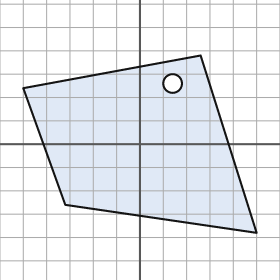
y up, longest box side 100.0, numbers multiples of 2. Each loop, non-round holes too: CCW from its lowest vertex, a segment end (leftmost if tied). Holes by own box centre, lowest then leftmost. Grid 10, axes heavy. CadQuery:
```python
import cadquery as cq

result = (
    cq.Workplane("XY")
    .moveTo(50.0, -38.0)
    .lineTo(26.0, 38.0)
    .lineTo(-50.0, 24.0)
    .lineTo(-32.0, -26.0)
    .close()
    .moveTo(14.0, 26.0)
    .circle(4.0)
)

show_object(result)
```